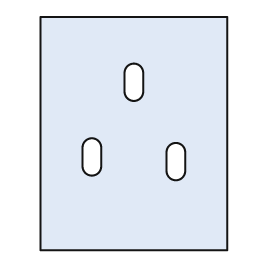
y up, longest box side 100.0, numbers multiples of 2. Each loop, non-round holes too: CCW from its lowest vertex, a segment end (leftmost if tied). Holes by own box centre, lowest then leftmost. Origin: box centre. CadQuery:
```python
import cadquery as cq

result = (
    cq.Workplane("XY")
    .moveTo(-40.0, -50.0)
    .lineTo(40.0, -50.0)
    .lineTo(40.0, 50.0)
    .lineTo(-40.0, 50.0)
    .close()
    .moveTo(14.0, -16.0)
    .threePointArc((18.0, -20.0), (22.0, -16.0))
    .lineTo(22.0, -8.0)
    .threePointArc((18.0, -4.0), (14.0, -8.0))
    .close()
    .moveTo(-22.0, -14.0)
    .threePointArc((-18.0, -18.0), (-14.0, -14.0))
    .lineTo(-14.0, -6.0)
    .threePointArc((-18.0, -2.0), (-22.0, -6.0))
    .close()
    .moveTo(-4.0, 18.0)
    .threePointArc((0.0, 14.0), (4.0, 18.0))
    .lineTo(4.0, 26.0)
    .threePointArc((0.0, 30.0), (-4.0, 26.0))
    .close()
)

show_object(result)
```